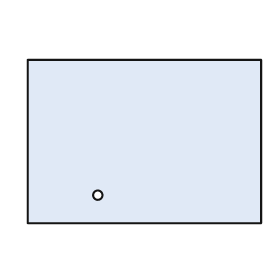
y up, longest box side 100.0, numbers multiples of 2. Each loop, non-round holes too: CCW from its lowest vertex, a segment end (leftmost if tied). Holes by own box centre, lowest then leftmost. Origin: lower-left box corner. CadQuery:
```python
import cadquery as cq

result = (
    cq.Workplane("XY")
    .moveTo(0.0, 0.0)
    .lineTo(100.0, 0.0)
    .lineTo(100.0, 70.0)
    .lineTo(0.0, 70.0)
    .close()
    .moveTo(30.0, 12.0)
    .circle(2.0)
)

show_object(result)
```